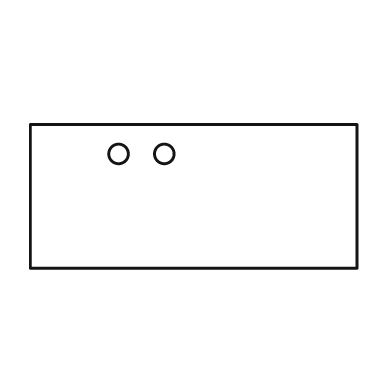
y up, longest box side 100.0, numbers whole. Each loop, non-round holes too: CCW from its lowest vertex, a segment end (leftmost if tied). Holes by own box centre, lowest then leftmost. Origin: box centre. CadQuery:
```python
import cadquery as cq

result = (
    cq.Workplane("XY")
    .moveTo(-50.0, -22.0)
    .lineTo(50.0, -22.0)
    .lineTo(50.0, 22.0)
    .lineTo(-50.0, 22.0)
    .close()
    .moveTo(-23.0, 13.0)
    .circle(3.0)
    .moveTo(-9.0, 13.0)
    .circle(3.0)
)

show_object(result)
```